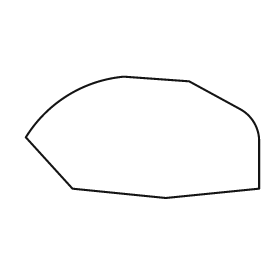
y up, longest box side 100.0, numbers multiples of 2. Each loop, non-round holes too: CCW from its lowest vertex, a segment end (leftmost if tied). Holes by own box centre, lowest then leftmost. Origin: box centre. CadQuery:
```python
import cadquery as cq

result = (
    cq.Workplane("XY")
    .moveTo(10.0, -26.0)
    .lineTo(50.0, -22.0)
    .lineTo(50.0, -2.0)
    .threePointArc((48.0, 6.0), (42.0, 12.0))
    .lineTo(20.0, 24.0)
    .lineTo(-8.0, 26.0)
    .threePointArc((-32.0, 18.0), (-50.0, 0.0))
    .lineTo(-30.0, -22.0)
    .close()
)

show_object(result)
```